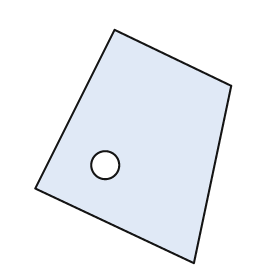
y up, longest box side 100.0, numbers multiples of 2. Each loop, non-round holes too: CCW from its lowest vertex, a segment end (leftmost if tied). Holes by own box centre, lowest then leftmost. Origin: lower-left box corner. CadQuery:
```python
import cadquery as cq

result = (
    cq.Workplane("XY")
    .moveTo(68.0, 0.0)
    .lineTo(84.0, 76.0)
    .lineTo(34.0, 100.0)
    .lineTo(0.0, 32.0)
    .close()
    .moveTo(30.0, 42.0)
    .circle(6.0)
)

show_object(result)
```